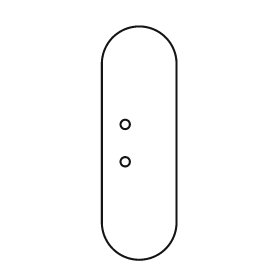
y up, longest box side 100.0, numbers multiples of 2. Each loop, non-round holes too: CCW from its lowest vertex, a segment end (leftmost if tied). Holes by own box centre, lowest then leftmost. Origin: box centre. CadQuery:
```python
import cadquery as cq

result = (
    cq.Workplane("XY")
    .moveTo(-16.0, -34.0)
    .threePointArc((0.0, -50.0), (16.0, -34.0))
    .lineTo(16.0, 34.0)
    .threePointArc((0.0, 50.0), (-16.0, 34.0))
    .close()
    .moveTo(-6.0, -8.0)
    .circle(2.0)
    .moveTo(-6.0, 8.0)
    .circle(2.0)
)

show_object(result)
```